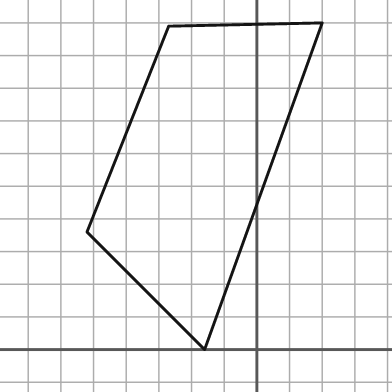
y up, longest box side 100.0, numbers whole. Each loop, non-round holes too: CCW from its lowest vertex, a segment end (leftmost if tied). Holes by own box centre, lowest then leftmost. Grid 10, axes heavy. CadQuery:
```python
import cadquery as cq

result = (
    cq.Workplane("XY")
    .moveTo(-16.0, 0.0)
    .lineTo(20.0, 100.0)
    .lineTo(-27.0, 99.0)
    .lineTo(-52.0, 36.0)
    .close()
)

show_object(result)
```